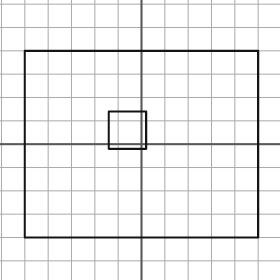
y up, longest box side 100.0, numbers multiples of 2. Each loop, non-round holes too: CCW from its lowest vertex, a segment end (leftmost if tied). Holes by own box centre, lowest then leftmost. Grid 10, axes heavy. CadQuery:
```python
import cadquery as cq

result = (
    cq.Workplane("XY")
    .moveTo(-50.0, -40.0)
    .lineTo(50.0, -40.0)
    .lineTo(50.0, 40.0)
    .lineTo(-50.0, 40.0)
    .close()
    .moveTo(-14.0, -2.0)
    .lineTo(2.0, -2.0)
    .lineTo(2.0, 14.0)
    .lineTo(-14.0, 14.0)
    .close()
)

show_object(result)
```